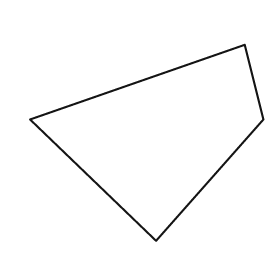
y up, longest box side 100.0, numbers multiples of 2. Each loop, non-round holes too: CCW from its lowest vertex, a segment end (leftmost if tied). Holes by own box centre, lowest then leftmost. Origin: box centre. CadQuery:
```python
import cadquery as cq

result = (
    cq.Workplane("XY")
    .moveTo(4.0, -42.0)
    .lineTo(50.0, 10.0)
    .lineTo(42.0, 42.0)
    .lineTo(-50.0, 10.0)
    .close()
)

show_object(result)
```